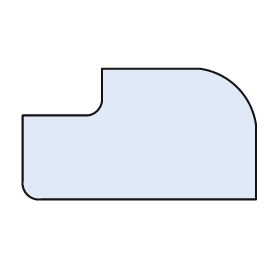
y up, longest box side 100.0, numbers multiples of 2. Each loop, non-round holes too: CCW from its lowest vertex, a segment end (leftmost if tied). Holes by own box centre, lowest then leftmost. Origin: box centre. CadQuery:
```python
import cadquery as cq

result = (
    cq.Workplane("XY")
    .moveTo(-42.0, -28.0)
    .lineTo(50.0, -28.0)
    .lineTo(50.0, 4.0)
    .threePointArc((42.0, 20.0), (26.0, 28.0))
    .lineTo(-16.0, 28.0)
    .lineTo(-16.0, 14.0)
    .threePointArc((-18.0, 10.0), (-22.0, 8.0))
    .lineTo(-50.0, 8.0)
    .lineTo(-50.0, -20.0)
    .threePointArc((-48.0, -26.0), (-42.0, -28.0))
    .close()
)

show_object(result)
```